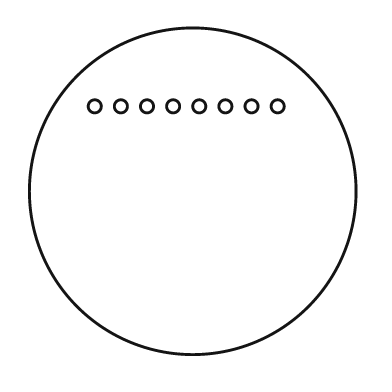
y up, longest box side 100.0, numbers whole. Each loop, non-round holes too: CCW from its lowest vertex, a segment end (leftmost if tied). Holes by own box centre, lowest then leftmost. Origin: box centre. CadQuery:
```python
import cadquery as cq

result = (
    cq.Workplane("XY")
    .moveTo(0.0, 0.0)
    .circle(50.0)
    .moveTo(-30.0, 26.0)
    .circle(2.0)
    .moveTo(-22.0, 26.0)
    .circle(2.0)
    .moveTo(-14.0, 26.0)
    .circle(2.0)
    .moveTo(-6.0, 26.0)
    .circle(2.0)
    .moveTo(2.0, 26.0)
    .circle(2.0)
    .moveTo(10.0, 26.0)
    .circle(2.0)
    .moveTo(18.0, 26.0)
    .circle(2.0)
    .moveTo(26.0, 26.0)
    .circle(2.0)
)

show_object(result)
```